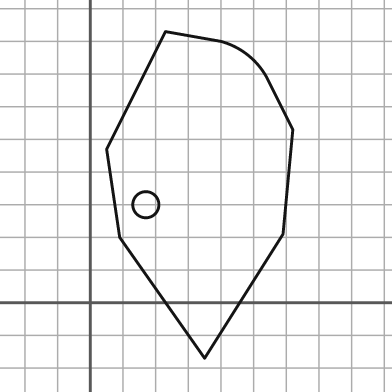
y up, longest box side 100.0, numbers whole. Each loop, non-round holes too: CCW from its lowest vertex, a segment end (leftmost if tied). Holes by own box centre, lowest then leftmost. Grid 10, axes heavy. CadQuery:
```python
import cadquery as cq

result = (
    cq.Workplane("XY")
    .moveTo(35.0, -17.0)
    .lineTo(59.0, 21.0)
    .lineTo(62.0, 53.0)
    .lineTo(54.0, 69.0)
    .threePointArc((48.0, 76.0), (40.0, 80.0))
    .lineTo(23.0, 83.0)
    .lineTo(5.0, 47.0)
    .lineTo(9.0, 20.0)
    .close()
    .moveTo(17.0, 30.0)
    .circle(4.0)
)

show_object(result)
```